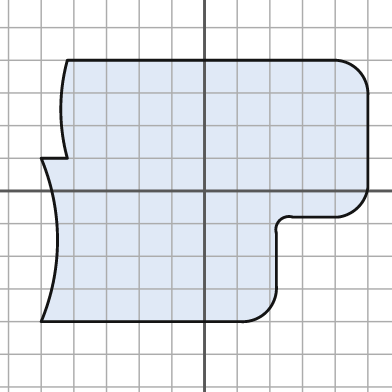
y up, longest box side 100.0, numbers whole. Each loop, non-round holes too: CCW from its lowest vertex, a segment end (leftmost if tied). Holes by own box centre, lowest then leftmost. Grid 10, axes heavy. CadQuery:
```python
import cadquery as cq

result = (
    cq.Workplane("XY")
    .moveTo(-50.0, -40.0)
    .lineTo(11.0, -40.0)
    .threePointArc((19.0, -37.0), (22.0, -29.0))
    .lineTo(22.0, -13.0)
    .threePointArc((23.0, -9.0), (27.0, -8.0))
    .lineTo(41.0, -8.0)
    .threePointArc((47.0, -5.0), (50.0, 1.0))
    .lineTo(50.0, 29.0)
    .threePointArc((47.0, 37.0), (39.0, 40.0))
    .lineTo(-42.0, 40.0)
    .threePointArc((-44.0, 25.0), (-42.0, 10.0))
    .lineTo(-50.0, 10.0)
    .threePointArc((-45.0, -15.0), (-50.0, -40.0))
    .close()
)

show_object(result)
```